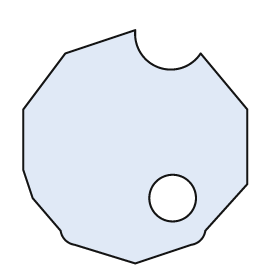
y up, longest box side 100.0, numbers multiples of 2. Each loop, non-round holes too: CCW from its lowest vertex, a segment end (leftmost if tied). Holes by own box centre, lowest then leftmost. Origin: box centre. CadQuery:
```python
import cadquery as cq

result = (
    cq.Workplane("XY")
    .moveTo(0.0, -50.0)
    .lineTo(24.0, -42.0)
    .threePointArc((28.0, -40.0), (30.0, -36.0))
    .lineTo(48.0, -16.0)
    .lineTo(48.0, 16.0)
    .lineTo(28.0, 40.0)
    .threePointArc((10.0, 34.0), (0.0, 50.0))
    .lineTo(-30.0, 40.0)
    .lineTo(-48.0, 16.0)
    .lineTo(-48.0, -10.0)
    .lineTo(-44.0, -22.0)
    .lineTo(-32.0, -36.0)
    .threePointArc((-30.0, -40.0), (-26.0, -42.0))
    .close()
    .moveTo(16.0, -22.0)
    .circle(10.0)
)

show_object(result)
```